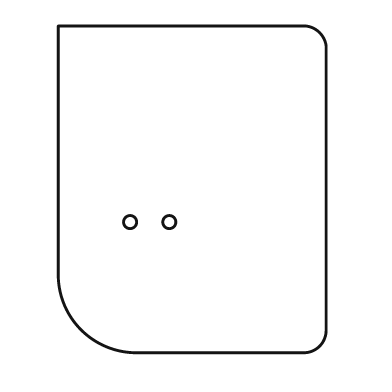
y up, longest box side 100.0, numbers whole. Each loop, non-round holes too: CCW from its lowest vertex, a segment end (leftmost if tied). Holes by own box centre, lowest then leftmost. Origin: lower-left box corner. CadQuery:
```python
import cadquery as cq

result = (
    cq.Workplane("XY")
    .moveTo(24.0, 0.0)
    .lineTo(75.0, 0.0)
    .threePointArc((80.0, 2.0), (82.0, 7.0))
    .lineTo(82.0, 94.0)
    .threePointArc((80.0, 98.0), (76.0, 100.0))
    .lineTo(0.0, 100.0)
    .lineTo(0.0, 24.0)
    .threePointArc((7.0, 7.0), (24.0, 0.0))
    .close()
    .moveTo(22.0, 40.0)
    .circle(2.0)
    .moveTo(34.0, 40.0)
    .circle(2.0)
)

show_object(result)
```